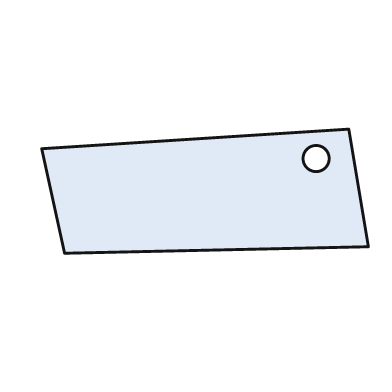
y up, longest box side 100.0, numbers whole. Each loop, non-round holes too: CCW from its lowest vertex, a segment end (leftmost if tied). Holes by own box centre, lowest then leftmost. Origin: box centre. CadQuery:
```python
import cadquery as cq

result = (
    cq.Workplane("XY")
    .moveTo(-43.0, -19.0)
    .lineTo(50.0, -17.0)
    .lineTo(44.0, 19.0)
    .lineTo(-50.0, 13.0)
    .close()
    .moveTo(34.0, 10.0)
    .circle(4.0)
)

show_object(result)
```